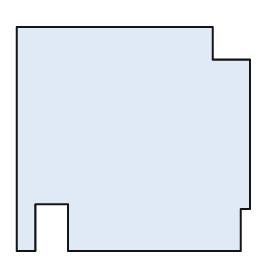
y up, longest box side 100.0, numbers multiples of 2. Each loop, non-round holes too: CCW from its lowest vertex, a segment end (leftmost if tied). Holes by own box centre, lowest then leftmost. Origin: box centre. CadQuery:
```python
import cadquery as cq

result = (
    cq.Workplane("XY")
    .moveTo(-50.0, -48.0)
    .lineTo(-42.0, -48.0)
    .lineTo(-42.0, -28.0)
    .lineTo(-28.0, -28.0)
    .lineTo(-28.0, -48.0)
    .lineTo(46.0, -48.0)
    .lineTo(46.0, -30.0)
    .lineTo(50.0, -30.0)
    .lineTo(50.0, 34.0)
    .lineTo(34.0, 34.0)
    .lineTo(34.0, 48.0)
    .lineTo(-50.0, 48.0)
    .close()
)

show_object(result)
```